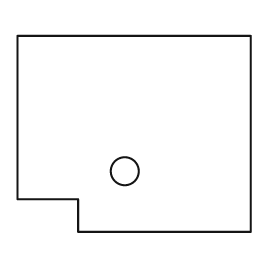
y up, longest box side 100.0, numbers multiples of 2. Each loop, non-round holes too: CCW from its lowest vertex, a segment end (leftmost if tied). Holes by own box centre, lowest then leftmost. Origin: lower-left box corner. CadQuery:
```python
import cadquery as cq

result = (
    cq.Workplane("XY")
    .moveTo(26.0, 0.0)
    .lineTo(100.0, 0.0)
    .lineTo(100.0, 84.0)
    .lineTo(0.0, 84.0)
    .lineTo(0.0, 14.0)
    .lineTo(26.0, 14.0)
    .close()
    .moveTo(46.0, 26.0)
    .circle(6.0)
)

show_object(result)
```